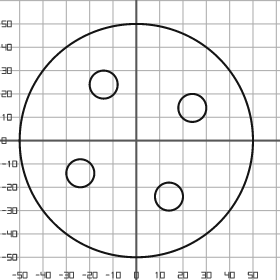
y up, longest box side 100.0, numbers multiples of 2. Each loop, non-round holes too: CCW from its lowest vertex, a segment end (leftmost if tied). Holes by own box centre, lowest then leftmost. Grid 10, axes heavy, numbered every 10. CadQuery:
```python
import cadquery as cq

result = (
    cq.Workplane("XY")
    .moveTo(0.0, 0.0)
    .circle(50.0)
    .moveTo(14.0, -24.0)
    .circle(6.0)
    .moveTo(-24.0, -14.0)
    .circle(6.0)
    .moveTo(24.0, 14.0)
    .circle(6.0)
    .moveTo(-14.0, 24.0)
    .circle(6.0)
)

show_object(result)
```